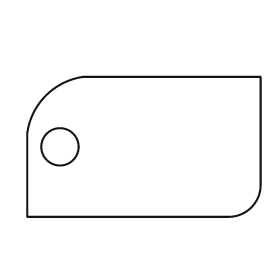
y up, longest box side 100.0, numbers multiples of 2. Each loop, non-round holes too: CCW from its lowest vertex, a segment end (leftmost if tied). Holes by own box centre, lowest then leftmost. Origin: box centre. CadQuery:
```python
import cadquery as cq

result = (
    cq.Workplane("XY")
    .moveTo(-50.0, -30.0)
    .lineTo(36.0, -30.0)
    .threePointArc((46.0, -26.0), (50.0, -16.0))
    .lineTo(50.0, 30.0)
    .lineTo(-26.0, 30.0)
    .threePointArc((-42.0, 22.0), (-50.0, 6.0))
    .close()
    .moveTo(-36.0, 0.0)
    .circle(8.0)
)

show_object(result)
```